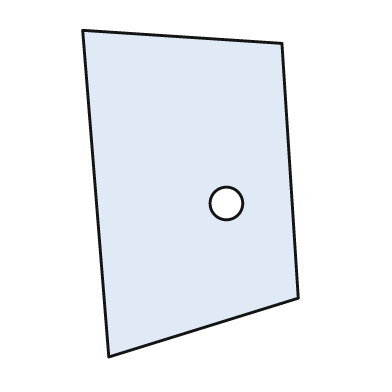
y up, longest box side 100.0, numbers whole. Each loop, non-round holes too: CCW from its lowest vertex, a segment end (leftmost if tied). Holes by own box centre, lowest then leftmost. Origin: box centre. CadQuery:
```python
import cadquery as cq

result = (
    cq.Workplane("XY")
    .moveTo(-25.0, -50.0)
    .lineTo(33.0, -32.0)
    .lineTo(28.0, 46.0)
    .lineTo(-33.0, 50.0)
    .close()
    .moveTo(11.0, -3.0)
    .circle(5.0)
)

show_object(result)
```